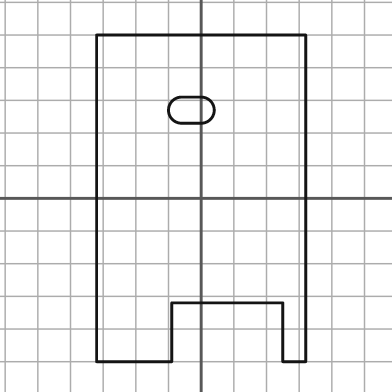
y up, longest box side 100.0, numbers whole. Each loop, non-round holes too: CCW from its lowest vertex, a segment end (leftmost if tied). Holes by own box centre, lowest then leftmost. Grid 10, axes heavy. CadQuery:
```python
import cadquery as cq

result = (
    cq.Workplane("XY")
    .moveTo(-32.0, -50.0)
    .lineTo(-9.0, -50.0)
    .lineTo(-9.0, -32.0)
    .lineTo(25.0, -32.0)
    .lineTo(25.0, -50.0)
    .lineTo(32.0, -50.0)
    .lineTo(32.0, 50.0)
    .lineTo(-32.0, 50.0)
    .close()
    .moveTo(-6.0, 23.0)
    .lineTo(0.0, 23.0)
    .threePointArc((4.0, 27.0), (0.0, 31.0))
    .lineTo(-6.0, 31.0)
    .threePointArc((-10.0, 27.0), (-6.0, 23.0))
    .close()
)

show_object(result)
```